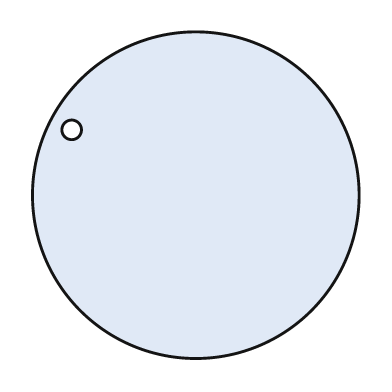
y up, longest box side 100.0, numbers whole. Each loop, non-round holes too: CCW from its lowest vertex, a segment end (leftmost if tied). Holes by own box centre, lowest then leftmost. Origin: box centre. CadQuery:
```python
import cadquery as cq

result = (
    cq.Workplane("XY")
    .moveTo(0.0, 0.0)
    .circle(50.0)
    .moveTo(-38.0, 20.0)
    .circle(3.0)
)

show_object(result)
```